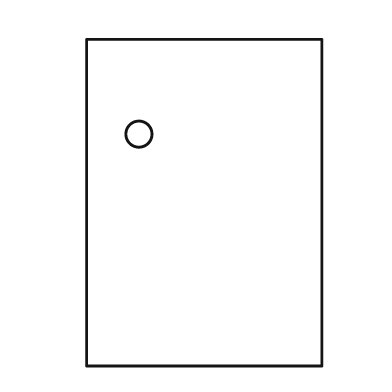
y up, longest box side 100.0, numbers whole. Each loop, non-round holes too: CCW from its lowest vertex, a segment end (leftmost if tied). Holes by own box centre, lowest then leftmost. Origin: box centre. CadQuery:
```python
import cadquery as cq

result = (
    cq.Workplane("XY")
    .moveTo(-36.0, -50.0)
    .lineTo(36.0, -50.0)
    .lineTo(36.0, 50.0)
    .lineTo(-36.0, 50.0)
    .close()
    .moveTo(-20.0, 21.0)
    .circle(4.0)
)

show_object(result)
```